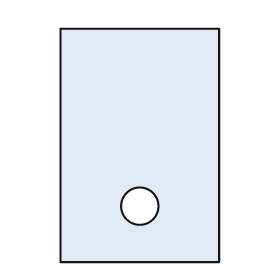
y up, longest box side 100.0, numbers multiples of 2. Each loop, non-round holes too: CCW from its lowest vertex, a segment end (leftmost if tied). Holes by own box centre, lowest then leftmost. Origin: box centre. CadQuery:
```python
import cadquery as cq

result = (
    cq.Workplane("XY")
    .moveTo(-34.0, -50.0)
    .lineTo(34.0, -50.0)
    .lineTo(34.0, 50.0)
    .lineTo(-34.0, 50.0)
    .close()
    .moveTo(0.0, -26.0)
    .circle(8.0)
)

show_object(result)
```